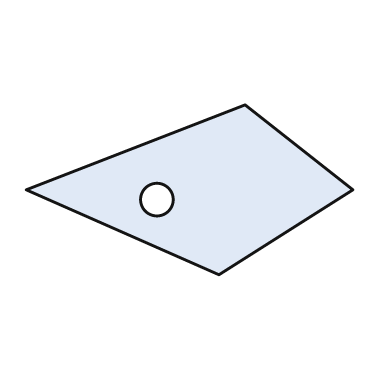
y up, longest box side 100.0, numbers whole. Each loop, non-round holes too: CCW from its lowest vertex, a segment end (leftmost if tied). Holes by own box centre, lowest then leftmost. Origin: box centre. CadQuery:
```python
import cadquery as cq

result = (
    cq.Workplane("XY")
    .moveTo(9.0, -26.0)
    .lineTo(50.0, 0.0)
    .lineTo(17.0, 26.0)
    .lineTo(-50.0, 0.0)
    .close()
    .moveTo(-10.0, -3.0)
    .circle(5.0)
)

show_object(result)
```